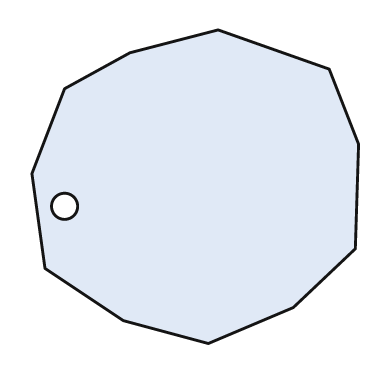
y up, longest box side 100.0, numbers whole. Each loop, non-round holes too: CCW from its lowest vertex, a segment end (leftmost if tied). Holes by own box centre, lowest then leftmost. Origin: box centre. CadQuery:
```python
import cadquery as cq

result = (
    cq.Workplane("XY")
    .moveTo(4.0, -48.0)
    .lineTo(30.0, -37.0)
    .lineTo(49.0, -19.0)
    .lineTo(50.0, 13.0)
    .lineTo(41.0, 36.0)
    .lineTo(7.0, 48.0)
    .lineTo(-20.0, 41.0)
    .lineTo(-40.0, 30.0)
    .lineTo(-50.0, 4.0)
    .lineTo(-46.0, -25.0)
    .lineTo(-22.0, -41.0)
    .close()
    .moveTo(-40.0, -6.0)
    .circle(4.0)
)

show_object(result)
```